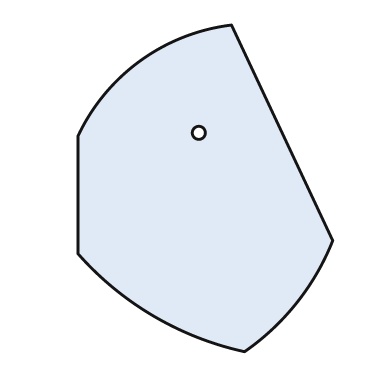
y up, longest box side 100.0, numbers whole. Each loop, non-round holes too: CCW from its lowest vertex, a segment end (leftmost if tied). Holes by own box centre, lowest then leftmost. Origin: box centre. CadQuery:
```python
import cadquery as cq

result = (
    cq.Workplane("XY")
    .moveTo(12.0, -50.0)
    .threePointArc((28.0, -35.0), (39.0, -16.0))
    .lineTo(8.0, 50.0)
    .threePointArc((-20.0, 39.0), (-39.0, 16.0))
    .lineTo(-39.0, -20.0)
    .threePointArc((-16.0, -39.0), (12.0, -50.0))
    .close()
    .moveTo(-2.0, 17.0)
    .circle(2.0)
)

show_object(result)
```